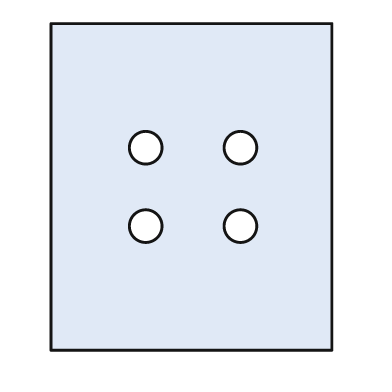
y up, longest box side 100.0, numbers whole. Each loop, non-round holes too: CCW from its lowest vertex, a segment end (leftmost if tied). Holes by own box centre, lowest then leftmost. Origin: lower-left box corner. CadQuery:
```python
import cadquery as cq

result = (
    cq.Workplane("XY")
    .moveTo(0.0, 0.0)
    .lineTo(86.0, 0.0)
    .lineTo(86.0, 100.0)
    .lineTo(0.0, 100.0)
    .close()
    .moveTo(29.0, 38.0)
    .circle(5.0)
    .moveTo(58.0, 38.0)
    .circle(5.0)
    .moveTo(29.0, 62.0)
    .circle(5.0)
    .moveTo(58.0, 62.0)
    .circle(5.0)
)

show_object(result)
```